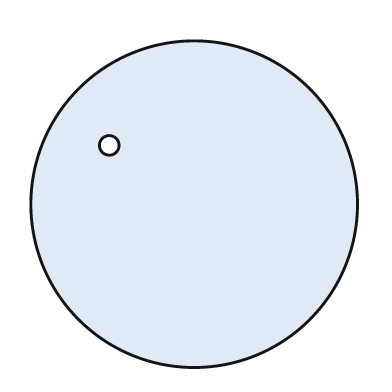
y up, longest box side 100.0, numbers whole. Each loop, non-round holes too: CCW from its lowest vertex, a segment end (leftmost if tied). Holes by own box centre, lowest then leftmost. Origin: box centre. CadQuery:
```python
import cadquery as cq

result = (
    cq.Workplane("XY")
    .moveTo(0.0, 0.0)
    .circle(50.0)
    .moveTo(-26.0, 18.0)
    .circle(3.0)
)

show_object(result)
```